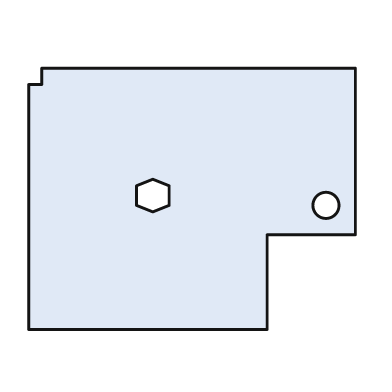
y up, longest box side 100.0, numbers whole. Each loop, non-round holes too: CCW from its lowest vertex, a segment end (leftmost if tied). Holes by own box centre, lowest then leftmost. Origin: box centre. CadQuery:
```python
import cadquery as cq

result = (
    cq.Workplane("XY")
    .moveTo(-50.0, -40.0)
    .lineTo(23.0, -40.0)
    .lineTo(23.0, -11.0)
    .lineTo(50.0, -11.0)
    .lineTo(50.0, 40.0)
    .lineTo(-46.0, 40.0)
    .lineTo(-46.0, 35.0)
    .lineTo(-50.0, 35.0)
    .close()
    .moveTo(41.0, -2.0)
    .circle(4.0)
    .moveTo(-12.0, -4.0)
    .lineTo(-7.0, -2.0)
    .lineTo(-7.0, 4.0)
    .lineTo(-12.0, 6.0)
    .lineTo(-17.0, 4.0)
    .lineTo(-17.0, -2.0)
    .close()
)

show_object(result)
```